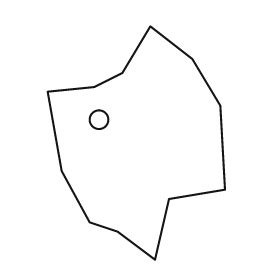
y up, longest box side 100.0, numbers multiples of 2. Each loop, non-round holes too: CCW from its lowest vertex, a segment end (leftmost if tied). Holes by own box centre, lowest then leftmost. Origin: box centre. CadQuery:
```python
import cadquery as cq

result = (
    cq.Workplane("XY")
    .moveTo(8.0, -50.0)
    .lineTo(14.0, -24.0)
    .lineTo(38.0, -20.0)
    .lineTo(36.0, 16.0)
    .lineTo(24.0, 36.0)
    .lineTo(6.0, 50.0)
    .lineTo(-6.0, 30.0)
    .lineTo(-18.0, 24.0)
    .lineTo(-38.0, 22.0)
    .lineTo(-32.0, -12.0)
    .lineTo(-20.0, -34.0)
    .lineTo(-8.0, -38.0)
    .close()
    .moveTo(-16.0, 10.0)
    .circle(4.0)
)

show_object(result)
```